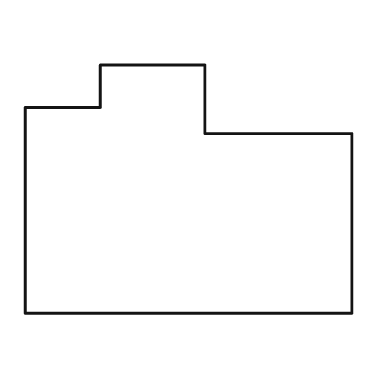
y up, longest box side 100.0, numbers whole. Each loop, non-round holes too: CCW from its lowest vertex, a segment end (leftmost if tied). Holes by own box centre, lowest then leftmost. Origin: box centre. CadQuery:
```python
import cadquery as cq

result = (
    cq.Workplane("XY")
    .moveTo(-50.0, -38.0)
    .lineTo(50.0, -38.0)
    .lineTo(50.0, 17.0)
    .lineTo(5.0, 17.0)
    .lineTo(5.0, 38.0)
    .lineTo(-27.0, 38.0)
    .lineTo(-27.0, 25.0)
    .lineTo(-50.0, 25.0)
    .close()
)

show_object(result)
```